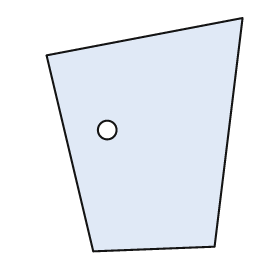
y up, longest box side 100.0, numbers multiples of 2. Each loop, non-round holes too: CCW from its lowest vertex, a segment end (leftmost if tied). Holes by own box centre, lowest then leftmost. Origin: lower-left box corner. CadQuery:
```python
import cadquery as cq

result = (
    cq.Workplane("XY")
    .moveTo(20.0, 0.0)
    .lineTo(72.0, 2.0)
    .lineTo(84.0, 100.0)
    .lineTo(0.0, 84.0)
    .close()
    .moveTo(26.0, 52.0)
    .circle(4.0)
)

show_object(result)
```